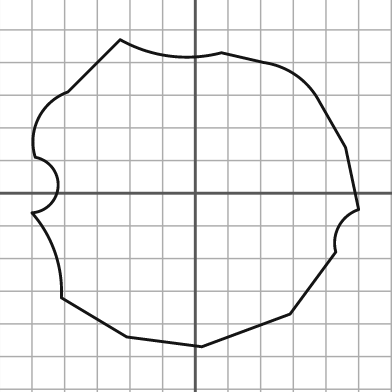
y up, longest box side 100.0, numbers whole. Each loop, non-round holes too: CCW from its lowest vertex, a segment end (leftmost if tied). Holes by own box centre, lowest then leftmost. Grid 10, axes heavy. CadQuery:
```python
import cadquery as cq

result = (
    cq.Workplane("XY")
    .moveTo(2.0, -47.0)
    .lineTo(29.0, -37.0)
    .lineTo(43.0, -18.0)
    .threePointArc((44.0, -10.0), (50.0, -5.0))
    .lineTo(46.0, 14.0)
    .lineTo(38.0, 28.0)
    .threePointArc((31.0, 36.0), (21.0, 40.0))
    .lineTo(8.0, 43.0)
    .threePointArc((-8.0, 42.0), (-23.0, 47.0))
    .lineTo(-39.0, 31.0)
    .threePointArc((-48.0, 23.0), (-49.0, 11.0))
    .threePointArc((-42.0, 2.0), (-50.0, -6.0))
    .threePointArc((-43.0, -18.0), (-41.0, -32.0))
    .lineTo(-21.0, -44.0)
    .close()
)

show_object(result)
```